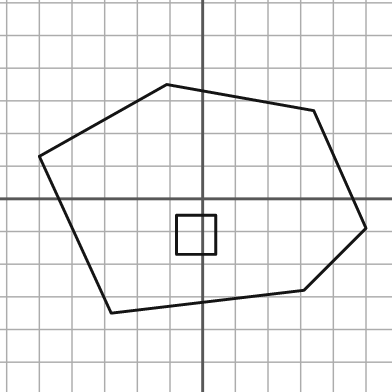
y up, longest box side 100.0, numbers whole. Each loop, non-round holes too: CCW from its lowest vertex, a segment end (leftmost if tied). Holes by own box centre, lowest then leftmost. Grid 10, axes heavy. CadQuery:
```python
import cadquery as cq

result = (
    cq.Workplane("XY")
    .moveTo(-28.0, -35.0)
    .lineTo(31.0, -28.0)
    .lineTo(50.0, -9.0)
    .lineTo(34.0, 27.0)
    .lineTo(-11.0, 35.0)
    .lineTo(-50.0, 13.0)
    .close()
    .moveTo(-8.0, -17.0)
    .lineTo(4.0, -17.0)
    .lineTo(4.0, -5.0)
    .lineTo(-8.0, -5.0)
    .close()
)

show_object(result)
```